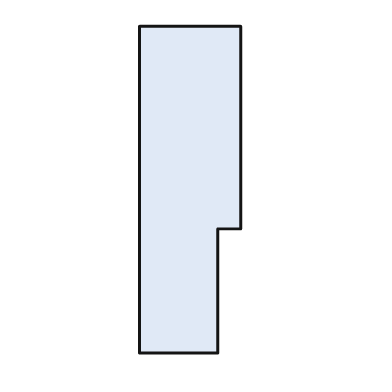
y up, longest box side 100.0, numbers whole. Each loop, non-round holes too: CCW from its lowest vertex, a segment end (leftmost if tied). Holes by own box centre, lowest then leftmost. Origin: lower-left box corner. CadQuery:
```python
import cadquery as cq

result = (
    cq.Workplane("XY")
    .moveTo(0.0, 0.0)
    .lineTo(24.0, 0.0)
    .lineTo(24.0, 38.0)
    .lineTo(31.0, 38.0)
    .lineTo(31.0, 100.0)
    .lineTo(0.0, 100.0)
    .close()
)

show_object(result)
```